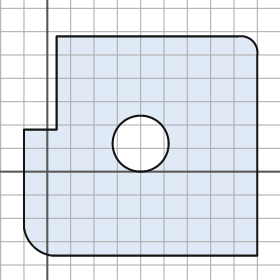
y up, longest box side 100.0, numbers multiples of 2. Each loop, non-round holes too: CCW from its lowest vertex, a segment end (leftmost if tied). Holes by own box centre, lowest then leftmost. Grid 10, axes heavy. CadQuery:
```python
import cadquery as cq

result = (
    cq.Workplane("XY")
    .moveTo(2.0, -36.0)
    .lineTo(90.0, -36.0)
    .lineTo(90.0, 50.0)
    .threePointArc((88.0, 56.0), (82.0, 58.0))
    .lineTo(4.0, 58.0)
    .lineTo(4.0, 18.0)
    .lineTo(-10.0, 18.0)
    .lineTo(-10.0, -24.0)
    .threePointArc((-6.0, -32.0), (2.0, -36.0))
    .close()
    .moveTo(40.0, 12.0)
    .circle(12.0)
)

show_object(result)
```